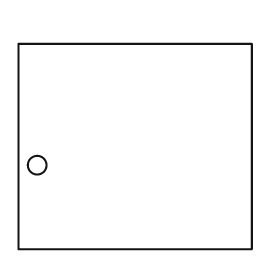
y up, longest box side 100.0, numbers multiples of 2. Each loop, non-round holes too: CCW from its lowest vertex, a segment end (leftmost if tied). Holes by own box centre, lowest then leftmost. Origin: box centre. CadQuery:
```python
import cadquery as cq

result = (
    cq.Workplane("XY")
    .moveTo(-50.0, -44.0)
    .lineTo(50.0, -44.0)
    .lineTo(50.0, 44.0)
    .lineTo(-50.0, 44.0)
    .close()
    .moveTo(-42.0, -8.0)
    .circle(4.0)
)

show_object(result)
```